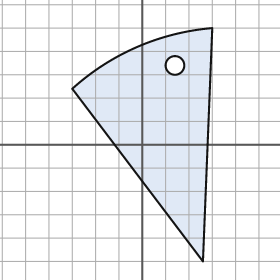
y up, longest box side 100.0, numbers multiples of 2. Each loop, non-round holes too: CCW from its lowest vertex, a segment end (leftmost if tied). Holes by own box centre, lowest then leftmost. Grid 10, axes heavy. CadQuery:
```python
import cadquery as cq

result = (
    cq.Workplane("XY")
    .moveTo(26.0, -50.0)
    .lineTo(30.0, 50.0)
    .threePointArc((-2.0, 42.0), (-30.0, 24.0))
    .close()
    .moveTo(14.0, 34.0)
    .circle(4.0)
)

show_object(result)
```